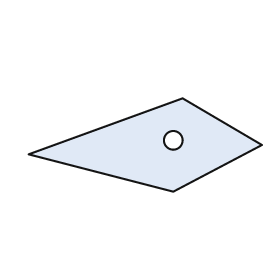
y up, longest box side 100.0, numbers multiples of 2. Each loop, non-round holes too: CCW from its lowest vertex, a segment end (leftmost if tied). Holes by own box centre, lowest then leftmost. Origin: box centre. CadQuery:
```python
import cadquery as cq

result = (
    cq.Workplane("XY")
    .moveTo(12.0, -20.0)
    .lineTo(50.0, 0.0)
    .lineTo(16.0, 20.0)
    .lineTo(-50.0, -4.0)
    .close()
    .moveTo(12.0, 2.0)
    .circle(4.0)
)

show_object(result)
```